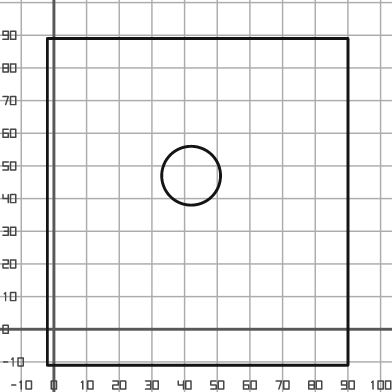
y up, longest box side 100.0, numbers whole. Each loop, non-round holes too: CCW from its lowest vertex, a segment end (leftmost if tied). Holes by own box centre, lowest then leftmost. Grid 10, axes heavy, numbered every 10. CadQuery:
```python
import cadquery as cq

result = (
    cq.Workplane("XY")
    .moveTo(-2.0, -11.0)
    .lineTo(90.0, -11.0)
    .lineTo(90.0, 89.0)
    .lineTo(-2.0, 89.0)
    .close()
    .moveTo(42.0, 47.0)
    .circle(9.0)
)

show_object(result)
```